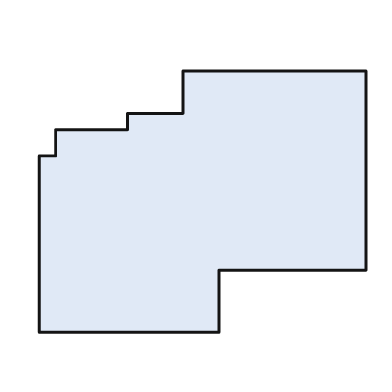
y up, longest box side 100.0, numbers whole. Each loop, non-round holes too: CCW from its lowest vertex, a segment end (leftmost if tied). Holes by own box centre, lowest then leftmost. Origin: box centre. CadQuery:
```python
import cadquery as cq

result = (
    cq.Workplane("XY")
    .moveTo(-50.0, -40.0)
    .lineTo(5.0, -40.0)
    .lineTo(5.0, -21.0)
    .lineTo(50.0, -21.0)
    .lineTo(50.0, 40.0)
    .lineTo(-6.0, 40.0)
    .lineTo(-6.0, 27.0)
    .lineTo(-23.0, 27.0)
    .lineTo(-23.0, 22.0)
    .lineTo(-45.0, 22.0)
    .lineTo(-45.0, 14.0)
    .lineTo(-50.0, 14.0)
    .close()
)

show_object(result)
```